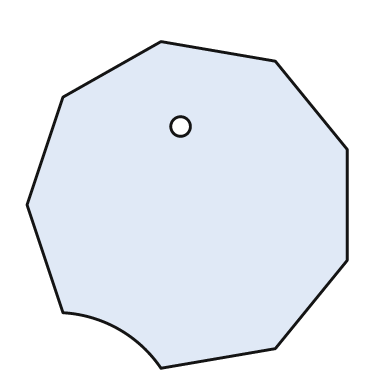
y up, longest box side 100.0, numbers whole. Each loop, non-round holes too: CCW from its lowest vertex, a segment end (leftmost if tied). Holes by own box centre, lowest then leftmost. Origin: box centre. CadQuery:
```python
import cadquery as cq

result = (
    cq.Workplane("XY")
    .moveTo(-8.0, -50.0)
    .lineTo(27.0, -44.0)
    .lineTo(49.0, -17.0)
    .lineTo(49.0, 17.0)
    .lineTo(27.0, 44.0)
    .lineTo(-8.0, 50.0)
    .lineTo(-38.0, 33.0)
    .lineTo(-49.0, 0.0)
    .lineTo(-38.0, -33.0)
    .threePointArc((-21.0, -38.0), (-8.0, -50.0))
    .close()
    .moveTo(-2.0, 24.0)
    .circle(3.0)
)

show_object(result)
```